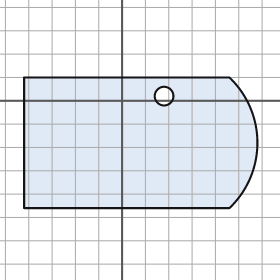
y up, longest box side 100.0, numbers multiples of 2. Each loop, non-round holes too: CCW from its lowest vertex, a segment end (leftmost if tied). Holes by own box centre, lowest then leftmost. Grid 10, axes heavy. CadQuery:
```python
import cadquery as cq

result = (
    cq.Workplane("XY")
    .moveTo(-42.0, -46.0)
    .lineTo(46.0, -46.0)
    .threePointArc((58.0, -18.0), (46.0, 10.0))
    .lineTo(-42.0, 10.0)
    .close()
    .moveTo(18.0, 2.0)
    .circle(4.0)
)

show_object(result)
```